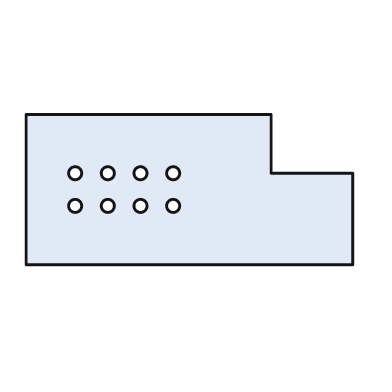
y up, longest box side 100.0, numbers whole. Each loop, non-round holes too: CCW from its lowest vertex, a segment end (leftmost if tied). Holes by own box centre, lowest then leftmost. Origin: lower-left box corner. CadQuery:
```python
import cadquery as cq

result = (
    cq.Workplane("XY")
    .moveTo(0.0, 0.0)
    .lineTo(100.0, 0.0)
    .lineTo(100.0, 28.0)
    .lineTo(75.0, 28.0)
    .lineTo(75.0, 46.0)
    .lineTo(0.0, 46.0)
    .close()
    .moveTo(15.0, 18.0)
    .circle(2.0)
    .moveTo(25.0, 18.0)
    .circle(2.0)
    .moveTo(35.0, 18.0)
    .circle(2.0)
    .moveTo(45.0, 18.0)
    .circle(2.0)
    .moveTo(15.0, 28.0)
    .circle(2.0)
    .moveTo(25.0, 28.0)
    .circle(2.0)
    .moveTo(35.0, 28.0)
    .circle(2.0)
    .moveTo(45.0, 28.0)
    .circle(2.0)
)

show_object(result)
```